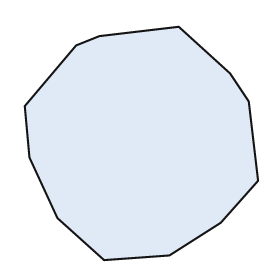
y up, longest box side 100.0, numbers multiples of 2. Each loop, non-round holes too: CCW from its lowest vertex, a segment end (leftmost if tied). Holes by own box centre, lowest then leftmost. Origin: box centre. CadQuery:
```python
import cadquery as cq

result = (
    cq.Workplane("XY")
    .moveTo(-16.0, -50.0)
    .lineTo(12.0, -48.0)
    .lineTo(34.0, -34.0)
    .lineTo(50.0, -16.0)
    .lineTo(46.0, 18.0)
    .lineTo(38.0, 30.0)
    .lineTo(16.0, 50.0)
    .lineTo(-18.0, 46.0)
    .lineTo(-28.0, 42.0)
    .lineTo(-50.0, 16.0)
    .lineTo(-48.0, -6.0)
    .lineTo(-36.0, -32.0)
    .close()
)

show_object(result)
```